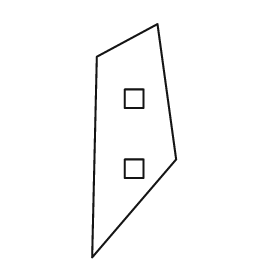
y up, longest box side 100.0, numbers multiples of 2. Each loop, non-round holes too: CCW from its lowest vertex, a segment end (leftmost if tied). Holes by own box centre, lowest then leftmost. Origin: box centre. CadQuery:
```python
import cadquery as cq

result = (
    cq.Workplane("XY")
    .moveTo(-18.0, -50.0)
    .lineTo(18.0, -8.0)
    .lineTo(10.0, 50.0)
    .lineTo(-16.0, 36.0)
    .close()
    .moveTo(-4.0, -16.0)
    .lineTo(4.0, -16.0)
    .lineTo(4.0, -8.0)
    .lineTo(-4.0, -8.0)
    .close()
    .moveTo(-4.0, 14.0)
    .lineTo(4.0, 14.0)
    .lineTo(4.0, 22.0)
    .lineTo(-4.0, 22.0)
    .close()
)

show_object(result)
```